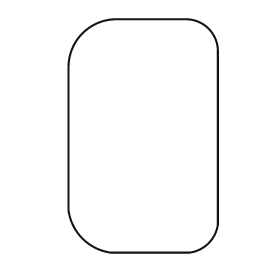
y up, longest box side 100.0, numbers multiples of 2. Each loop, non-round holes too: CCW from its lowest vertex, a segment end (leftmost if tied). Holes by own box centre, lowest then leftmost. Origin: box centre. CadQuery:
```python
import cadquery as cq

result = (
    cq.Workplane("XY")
    .moveTo(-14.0, -50.0)
    .lineTo(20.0, -50.0)
    .threePointArc((28.0, -46.0), (32.0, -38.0))
    .lineTo(32.0, 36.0)
    .threePointArc((28.0, 46.0), (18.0, 50.0))
    .lineTo(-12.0, 50.0)
    .threePointArc((-26.0, 44.0), (-32.0, 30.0))
    .lineTo(-32.0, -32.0)
    .threePointArc((-26.0, -44.0), (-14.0, -50.0))
    .close()
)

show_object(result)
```